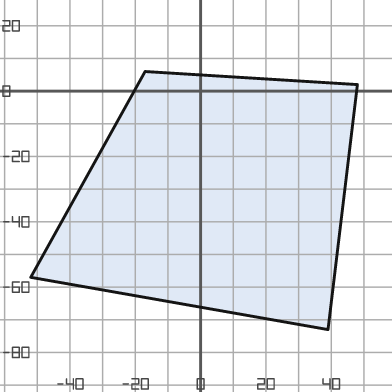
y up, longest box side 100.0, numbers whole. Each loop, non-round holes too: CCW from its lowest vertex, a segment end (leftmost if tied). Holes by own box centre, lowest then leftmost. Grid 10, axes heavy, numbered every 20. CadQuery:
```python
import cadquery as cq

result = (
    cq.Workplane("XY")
    .moveTo(39.0, -73.0)
    .lineTo(48.0, 2.0)
    .lineTo(-17.0, 6.0)
    .lineTo(-52.0, -57.0)
    .close()
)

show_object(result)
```